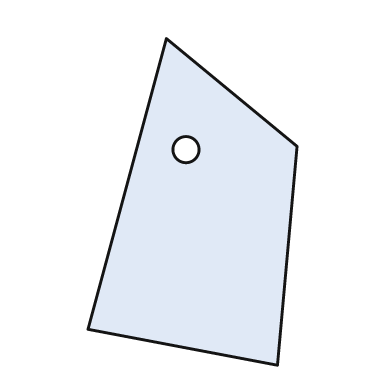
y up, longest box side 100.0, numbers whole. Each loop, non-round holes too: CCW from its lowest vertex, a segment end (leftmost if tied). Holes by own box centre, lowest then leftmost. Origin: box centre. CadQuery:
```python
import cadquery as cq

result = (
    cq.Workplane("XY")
    .moveTo(26.0, -50.0)
    .lineTo(32.0, 17.0)
    .lineTo(-8.0, 50.0)
    .lineTo(-32.0, -39.0)
    .close()
    .moveTo(-2.0, 16.0)
    .circle(4.0)
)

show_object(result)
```